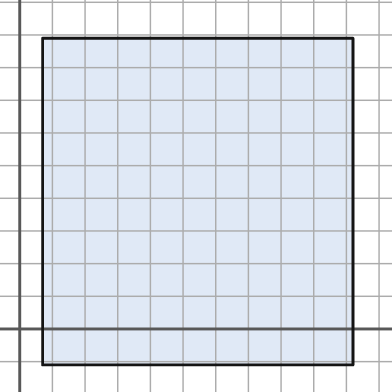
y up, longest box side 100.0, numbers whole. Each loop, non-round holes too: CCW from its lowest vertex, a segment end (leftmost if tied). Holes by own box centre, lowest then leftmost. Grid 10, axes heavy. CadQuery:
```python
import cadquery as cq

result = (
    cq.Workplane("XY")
    .moveTo(7.0, -11.0)
    .lineTo(102.0, -11.0)
    .lineTo(102.0, 89.0)
    .lineTo(7.0, 89.0)
    .close()
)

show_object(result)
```